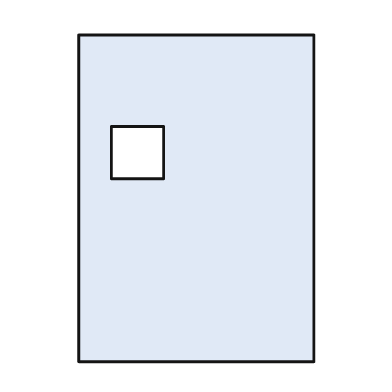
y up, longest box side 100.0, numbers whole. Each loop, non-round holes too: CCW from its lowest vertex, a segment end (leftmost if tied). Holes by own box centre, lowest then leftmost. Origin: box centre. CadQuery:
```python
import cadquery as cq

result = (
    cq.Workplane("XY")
    .moveTo(-36.0, -50.0)
    .lineTo(36.0, -50.0)
    .lineTo(36.0, 50.0)
    .lineTo(-36.0, 50.0)
    .close()
    .moveTo(-26.0, 6.0)
    .lineTo(-10.0, 6.0)
    .lineTo(-10.0, 22.0)
    .lineTo(-26.0, 22.0)
    .close()
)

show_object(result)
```